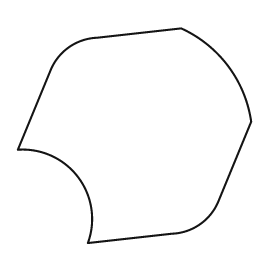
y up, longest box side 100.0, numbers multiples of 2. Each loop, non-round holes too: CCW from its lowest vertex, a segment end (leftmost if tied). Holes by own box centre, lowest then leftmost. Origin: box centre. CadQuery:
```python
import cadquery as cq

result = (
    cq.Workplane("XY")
    .moveTo(-20.0, -46.0)
    .lineTo(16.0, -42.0)
    .threePointArc((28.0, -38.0), (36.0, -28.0))
    .lineTo(50.0, 6.0)
    .threePointArc((40.0, 30.0), (20.0, 46.0))
    .lineTo(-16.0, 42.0)
    .threePointArc((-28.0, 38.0), (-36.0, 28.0))
    .lineTo(-50.0, -6.0)
    .threePointArc((-24.0, -18.0), (-20.0, -46.0))
    .close()
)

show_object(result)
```